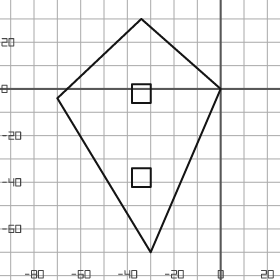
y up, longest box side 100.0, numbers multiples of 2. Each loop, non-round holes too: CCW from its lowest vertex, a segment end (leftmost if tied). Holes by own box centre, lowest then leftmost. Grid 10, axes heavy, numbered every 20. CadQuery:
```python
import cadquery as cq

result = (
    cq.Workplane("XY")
    .moveTo(-30.0, -70.0)
    .lineTo(0.0, 0.0)
    .lineTo(-34.0, 30.0)
    .lineTo(-70.0, -4.0)
    .close()
    .moveTo(-38.0, -42.0)
    .lineTo(-30.0, -42.0)
    .lineTo(-30.0, -34.0)
    .lineTo(-38.0, -34.0)
    .close()
    .moveTo(-38.0, -6.0)
    .lineTo(-30.0, -6.0)
    .lineTo(-30.0, 2.0)
    .lineTo(-38.0, 2.0)
    .close()
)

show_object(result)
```